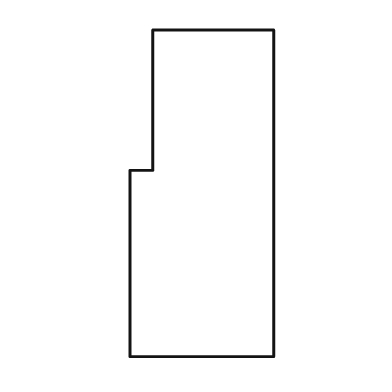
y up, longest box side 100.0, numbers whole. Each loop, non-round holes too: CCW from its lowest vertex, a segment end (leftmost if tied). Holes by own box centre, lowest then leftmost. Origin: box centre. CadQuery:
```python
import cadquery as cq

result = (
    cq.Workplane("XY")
    .moveTo(-22.0, -50.0)
    .lineTo(22.0, -50.0)
    .lineTo(22.0, 50.0)
    .lineTo(-15.0, 50.0)
    .lineTo(-15.0, 7.0)
    .lineTo(-22.0, 7.0)
    .close()
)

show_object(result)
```